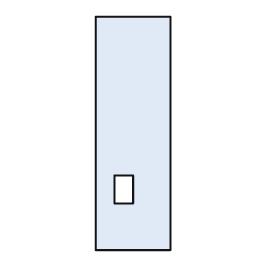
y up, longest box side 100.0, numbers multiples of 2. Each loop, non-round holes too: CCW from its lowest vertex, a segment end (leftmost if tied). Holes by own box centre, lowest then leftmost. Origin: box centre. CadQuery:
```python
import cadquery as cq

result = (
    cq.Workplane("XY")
    .moveTo(-16.0, -50.0)
    .lineTo(16.0, -50.0)
    .lineTo(16.0, 50.0)
    .lineTo(-16.0, 50.0)
    .close()
    .moveTo(-8.0, -30.0)
    .lineTo(0.0, -30.0)
    .lineTo(0.0, -18.0)
    .lineTo(-8.0, -18.0)
    .close()
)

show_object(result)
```